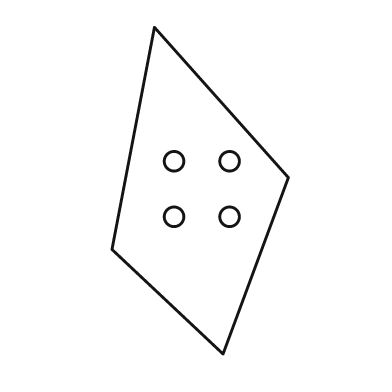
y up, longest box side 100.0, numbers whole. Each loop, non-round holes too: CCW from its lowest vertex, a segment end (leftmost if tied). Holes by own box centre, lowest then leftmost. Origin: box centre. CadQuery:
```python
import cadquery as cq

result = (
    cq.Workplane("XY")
    .moveTo(7.0, -50.0)
    .lineTo(27.0, 4.0)
    .lineTo(-14.0, 50.0)
    .lineTo(-27.0, -18.0)
    .close()
    .moveTo(-8.0, -8.0)
    .circle(3.0)
    .moveTo(9.0, -8.0)
    .circle(3.0)
    .moveTo(-8.0, 9.0)
    .circle(3.0)
    .moveTo(9.0, 9.0)
    .circle(3.0)
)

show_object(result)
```